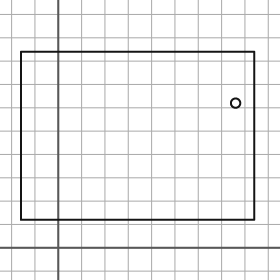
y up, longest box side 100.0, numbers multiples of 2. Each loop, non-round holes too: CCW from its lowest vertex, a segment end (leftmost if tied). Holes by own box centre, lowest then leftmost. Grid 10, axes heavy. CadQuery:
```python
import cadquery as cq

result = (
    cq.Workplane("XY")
    .moveTo(-16.0, 12.0)
    .lineTo(84.0, 12.0)
    .lineTo(84.0, 84.0)
    .lineTo(-16.0, 84.0)
    .close()
    .moveTo(76.0, 62.0)
    .circle(2.0)
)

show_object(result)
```